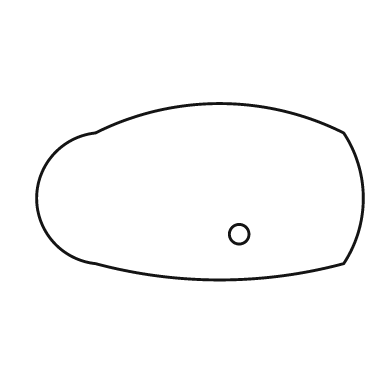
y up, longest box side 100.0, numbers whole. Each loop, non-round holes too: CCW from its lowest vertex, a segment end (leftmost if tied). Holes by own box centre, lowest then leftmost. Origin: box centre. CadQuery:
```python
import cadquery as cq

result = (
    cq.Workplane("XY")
    .moveTo(-32.0, -22.0)
    .threePointArc((6.0, -27.0), (44.0, -22.0))
    .threePointArc((50.0, -2.0), (44.0, 18.0))
    .threePointArc((6.0, 27.0), (-32.0, 18.0))
    .threePointArc((-50.0, -2.0), (-32.0, -22.0))
    .close()
    .moveTo(12.0, -13.0)
    .circle(3.0)
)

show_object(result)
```